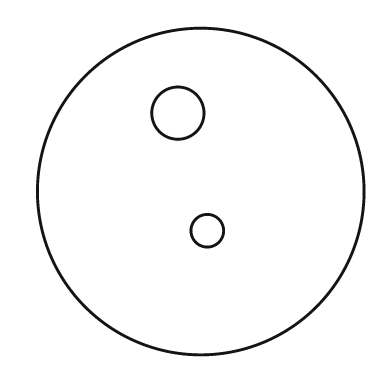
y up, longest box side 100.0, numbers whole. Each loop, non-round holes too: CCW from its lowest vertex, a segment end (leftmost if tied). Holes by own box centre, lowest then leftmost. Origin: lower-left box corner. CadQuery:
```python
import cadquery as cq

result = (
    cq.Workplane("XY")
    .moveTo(50.0, 50.0)
    .circle(50.0)
    .moveTo(52.0, 38.0)
    .circle(5.0)
    .moveTo(43.0, 74.0)
    .circle(8.0)
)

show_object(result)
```